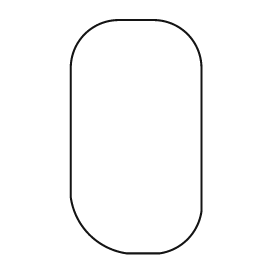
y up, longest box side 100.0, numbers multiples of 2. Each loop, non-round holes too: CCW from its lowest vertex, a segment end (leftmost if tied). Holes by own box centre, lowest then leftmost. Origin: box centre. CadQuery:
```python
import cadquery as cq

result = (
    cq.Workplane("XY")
    .moveTo(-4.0, -50.0)
    .lineTo(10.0, -50.0)
    .threePointArc((22.0, -44.0), (28.0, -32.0))
    .lineTo(28.0, 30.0)
    .threePointArc((22.0, 44.0), (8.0, 50.0))
    .lineTo(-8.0, 50.0)
    .threePointArc((-22.0, 44.0), (-28.0, 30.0))
    .lineTo(-28.0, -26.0)
    .threePointArc((-20.0, -42.0), (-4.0, -50.0))
    .close()
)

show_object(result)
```